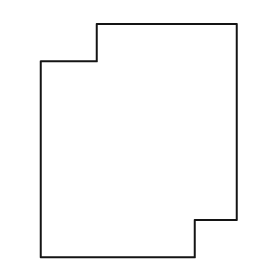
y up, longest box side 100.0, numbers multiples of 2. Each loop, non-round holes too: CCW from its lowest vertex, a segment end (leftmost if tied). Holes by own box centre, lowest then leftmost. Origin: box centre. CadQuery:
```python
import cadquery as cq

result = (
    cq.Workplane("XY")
    .moveTo(-42.0, -50.0)
    .lineTo(24.0, -50.0)
    .lineTo(24.0, -34.0)
    .lineTo(42.0, -34.0)
    .lineTo(42.0, 50.0)
    .lineTo(-18.0, 50.0)
    .lineTo(-18.0, 34.0)
    .lineTo(-42.0, 34.0)
    .close()
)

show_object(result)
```